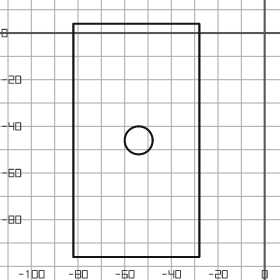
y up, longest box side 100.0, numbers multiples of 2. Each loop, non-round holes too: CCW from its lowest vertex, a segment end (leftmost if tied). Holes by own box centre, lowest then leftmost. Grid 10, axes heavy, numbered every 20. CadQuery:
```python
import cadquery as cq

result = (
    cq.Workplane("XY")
    .moveTo(-82.0, -96.0)
    .lineTo(-28.0, -96.0)
    .lineTo(-28.0, 4.0)
    .lineTo(-82.0, 4.0)
    .close()
    .moveTo(-54.0, -46.0)
    .circle(6.0)
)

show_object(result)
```